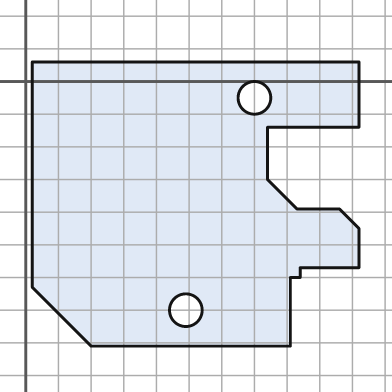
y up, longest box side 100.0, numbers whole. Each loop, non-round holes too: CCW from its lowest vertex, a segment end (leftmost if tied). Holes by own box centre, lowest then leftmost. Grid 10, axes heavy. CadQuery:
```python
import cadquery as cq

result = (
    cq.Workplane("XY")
    .moveTo(20.0, -81.0)
    .lineTo(81.0, -81.0)
    .lineTo(81.0, -60.0)
    .lineTo(84.0, -60.0)
    .lineTo(84.0, -57.0)
    .lineTo(102.0, -57.0)
    .lineTo(102.0, -45.0)
    .lineTo(96.0, -39.0)
    .lineTo(83.0, -39.0)
    .lineTo(74.0, -30.0)
    .lineTo(74.0, -14.0)
    .lineTo(102.0, -14.0)
    .lineTo(102.0, 6.0)
    .lineTo(2.0, 6.0)
    .lineTo(2.0, -63.0)
    .close()
    .moveTo(49.0, -70.0)
    .circle(5.0)
    .moveTo(70.0, -5.0)
    .circle(5.0)
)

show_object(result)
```